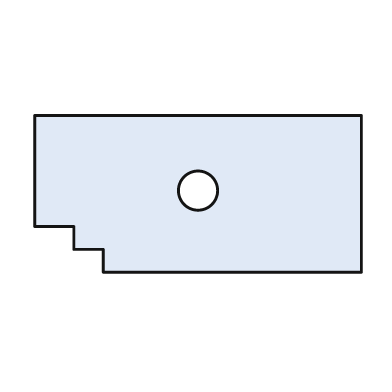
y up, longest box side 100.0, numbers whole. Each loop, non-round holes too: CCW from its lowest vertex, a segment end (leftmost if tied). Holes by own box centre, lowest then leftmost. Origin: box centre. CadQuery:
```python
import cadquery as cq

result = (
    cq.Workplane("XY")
    .moveTo(-29.0, -24.0)
    .lineTo(50.0, -24.0)
    .lineTo(50.0, 24.0)
    .lineTo(-50.0, 24.0)
    .lineTo(-50.0, -10.0)
    .lineTo(-38.0, -10.0)
    .lineTo(-38.0, -17.0)
    .lineTo(-29.0, -17.0)
    .close()
    .moveTo(0.0, 1.0)
    .circle(6.0)
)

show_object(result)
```